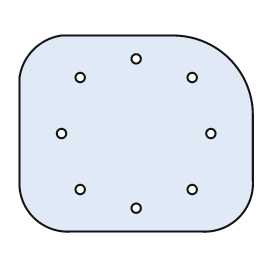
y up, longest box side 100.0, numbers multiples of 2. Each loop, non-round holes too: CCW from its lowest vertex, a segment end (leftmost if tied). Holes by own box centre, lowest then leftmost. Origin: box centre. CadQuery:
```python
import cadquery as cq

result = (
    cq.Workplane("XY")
    .moveTo(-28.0, -42.0)
    .lineTo(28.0, -42.0)
    .threePointArc((44.0, -36.0), (50.0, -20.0))
    .lineTo(50.0, 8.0)
    .threePointArc((40.0, 32.0), (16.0, 42.0))
    .lineTo(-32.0, 42.0)
    .threePointArc((-44.0, 36.0), (-50.0, 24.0))
    .lineTo(-50.0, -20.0)
    .threePointArc((-44.0, -36.0), (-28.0, -42.0))
    .close()
    .moveTo(0.0, -32.0)
    .circle(2.0)
    .moveTo(-24.0, -24.0)
    .circle(2.0)
    .moveTo(24.0, -24.0)
    .circle(2.0)
    .moveTo(-32.0, 0.0)
    .circle(2.0)
    .moveTo(32.0, 0.0)
    .circle(2.0)
    .moveTo(-24.0, 24.0)
    .circle(2.0)
    .moveTo(24.0, 24.0)
    .circle(2.0)
    .moveTo(0.0, 32.0)
    .circle(2.0)
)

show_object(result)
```